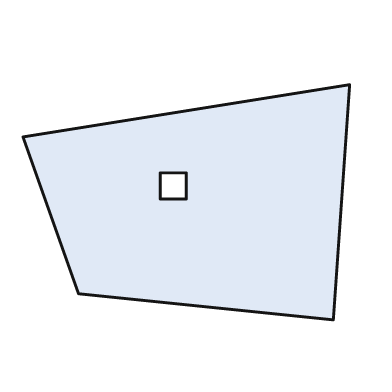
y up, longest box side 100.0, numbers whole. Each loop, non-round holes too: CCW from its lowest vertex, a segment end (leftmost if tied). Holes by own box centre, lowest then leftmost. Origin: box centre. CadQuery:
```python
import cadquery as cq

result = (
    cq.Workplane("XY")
    .moveTo(45.0, -36.0)
    .lineTo(50.0, 36.0)
    .lineTo(-50.0, 20.0)
    .lineTo(-33.0, -28.0)
    .close()
    .moveTo(-8.0, 1.0)
    .lineTo(0.0, 1.0)
    .lineTo(0.0, 9.0)
    .lineTo(-8.0, 9.0)
    .close()
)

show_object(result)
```